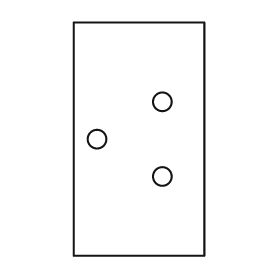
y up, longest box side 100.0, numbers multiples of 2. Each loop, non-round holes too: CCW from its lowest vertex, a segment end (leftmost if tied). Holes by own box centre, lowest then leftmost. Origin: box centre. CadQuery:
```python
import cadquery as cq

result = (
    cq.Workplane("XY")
    .moveTo(-28.0, -50.0)
    .lineTo(28.0, -50.0)
    .lineTo(28.0, 50.0)
    .lineTo(-28.0, 50.0)
    .close()
    .moveTo(10.0, -16.0)
    .circle(4.0)
    .moveTo(-18.0, 0.0)
    .circle(4.0)
    .moveTo(10.0, 16.0)
    .circle(4.0)
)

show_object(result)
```